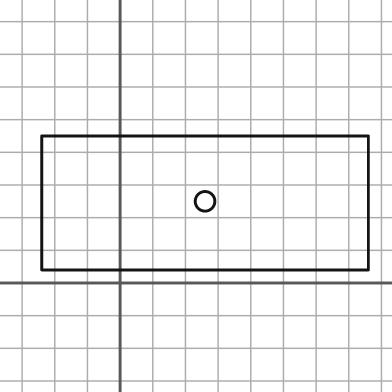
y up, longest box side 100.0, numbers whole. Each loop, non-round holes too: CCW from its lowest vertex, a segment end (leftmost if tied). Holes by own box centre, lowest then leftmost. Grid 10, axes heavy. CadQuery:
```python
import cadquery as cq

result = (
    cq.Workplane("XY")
    .moveTo(-24.0, 4.0)
    .lineTo(76.0, 4.0)
    .lineTo(76.0, 45.0)
    .lineTo(-24.0, 45.0)
    .close()
    .moveTo(26.0, 25.0)
    .circle(3.0)
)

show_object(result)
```